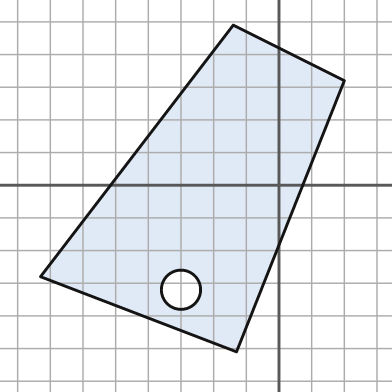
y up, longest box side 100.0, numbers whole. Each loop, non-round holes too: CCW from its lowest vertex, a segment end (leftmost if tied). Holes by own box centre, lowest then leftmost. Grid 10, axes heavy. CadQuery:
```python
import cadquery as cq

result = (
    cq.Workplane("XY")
    .moveTo(-13.0, -51.0)
    .lineTo(20.0, 32.0)
    .lineTo(-14.0, 49.0)
    .lineTo(-73.0, -28.0)
    .close()
    .moveTo(-30.0, -32.0)
    .circle(6.0)
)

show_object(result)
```